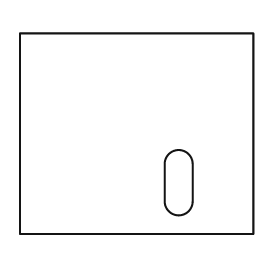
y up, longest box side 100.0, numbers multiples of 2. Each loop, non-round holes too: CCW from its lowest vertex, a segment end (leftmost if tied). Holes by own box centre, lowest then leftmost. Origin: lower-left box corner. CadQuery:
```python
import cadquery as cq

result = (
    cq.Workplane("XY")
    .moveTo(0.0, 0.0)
    .lineTo(100.0, 0.0)
    .lineTo(100.0, 86.0)
    .lineTo(0.0, 86.0)
    .close()
    .moveTo(62.0, 14.0)
    .threePointArc((68.0, 8.0), (74.0, 14.0))
    .lineTo(74.0, 30.0)
    .threePointArc((68.0, 36.0), (62.0, 30.0))
    .close()
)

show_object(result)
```